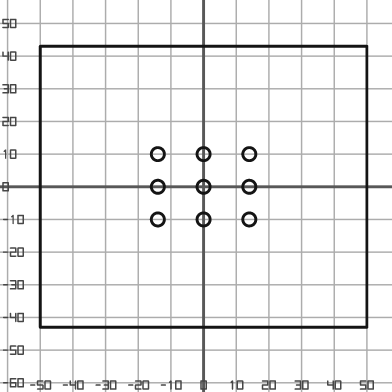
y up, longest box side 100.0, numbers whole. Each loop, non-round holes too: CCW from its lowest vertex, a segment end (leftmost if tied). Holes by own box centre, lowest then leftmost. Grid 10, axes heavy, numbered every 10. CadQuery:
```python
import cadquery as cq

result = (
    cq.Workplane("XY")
    .moveTo(-50.0, -43.0)
    .lineTo(50.0, -43.0)
    .lineTo(50.0, 43.0)
    .lineTo(-50.0, 43.0)
    .close()
    .moveTo(-14.0, -10.0)
    .circle(2.0)
    .moveTo(0.0, -10.0)
    .circle(2.0)
    .moveTo(14.0, -10.0)
    .circle(2.0)
    .moveTo(-14.0, 0.0)
    .circle(2.0)
    .moveTo(0.0, 0.0)
    .circle(2.0)
    .moveTo(14.0, 0.0)
    .circle(2.0)
    .moveTo(-14.0, 10.0)
    .circle(2.0)
    .moveTo(0.0, 10.0)
    .circle(2.0)
    .moveTo(14.0, 10.0)
    .circle(2.0)
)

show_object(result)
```